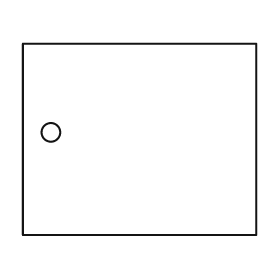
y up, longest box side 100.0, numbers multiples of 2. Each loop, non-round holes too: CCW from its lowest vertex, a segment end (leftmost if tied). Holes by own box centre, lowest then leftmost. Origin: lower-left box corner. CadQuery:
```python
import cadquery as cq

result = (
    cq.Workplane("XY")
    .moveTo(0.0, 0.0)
    .lineTo(100.0, 0.0)
    .lineTo(100.0, 82.0)
    .lineTo(0.0, 82.0)
    .close()
    .moveTo(12.0, 44.0)
    .circle(4.0)
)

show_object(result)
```